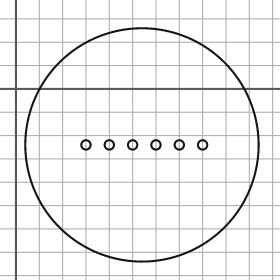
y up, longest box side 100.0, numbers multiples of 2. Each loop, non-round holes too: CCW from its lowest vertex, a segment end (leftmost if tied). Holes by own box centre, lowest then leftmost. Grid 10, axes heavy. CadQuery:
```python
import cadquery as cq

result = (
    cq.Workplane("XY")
    .moveTo(54.0, -24.0)
    .circle(50.0)
    .moveTo(30.0, -24.0)
    .circle(2.0)
    .moveTo(40.0, -24.0)
    .circle(2.0)
    .moveTo(50.0, -24.0)
    .circle(2.0)
    .moveTo(60.0, -24.0)
    .circle(2.0)
    .moveTo(70.0, -24.0)
    .circle(2.0)
    .moveTo(80.0, -24.0)
    .circle(2.0)
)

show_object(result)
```